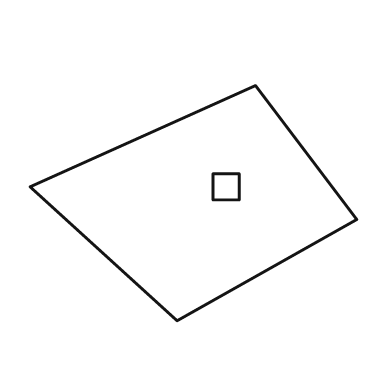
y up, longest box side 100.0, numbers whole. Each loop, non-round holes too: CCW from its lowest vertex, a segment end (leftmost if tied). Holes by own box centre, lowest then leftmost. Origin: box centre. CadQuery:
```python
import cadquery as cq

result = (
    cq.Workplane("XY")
    .moveTo(-5.0, -36.0)
    .lineTo(50.0, -5.0)
    .lineTo(19.0, 36.0)
    .lineTo(-50.0, 5.0)
    .close()
    .moveTo(6.0, 1.0)
    .lineTo(14.0, 1.0)
    .lineTo(14.0, 9.0)
    .lineTo(6.0, 9.0)
    .close()
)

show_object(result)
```